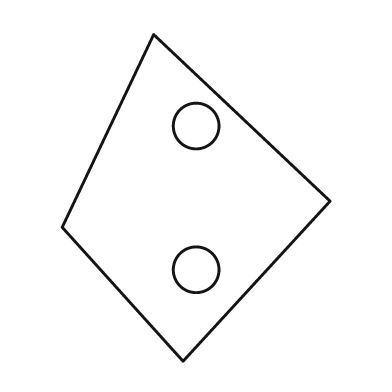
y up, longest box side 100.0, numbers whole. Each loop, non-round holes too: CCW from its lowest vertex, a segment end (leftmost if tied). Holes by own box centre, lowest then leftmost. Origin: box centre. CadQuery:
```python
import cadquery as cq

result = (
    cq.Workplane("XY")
    .moveTo(-4.0, -50.0)
    .lineTo(41.0, -1.0)
    .lineTo(-13.0, 50.0)
    .lineTo(-41.0, -9.0)
    .close()
    .moveTo(0.0, -22.0)
    .circle(7.0)
    .moveTo(0.0, 22.0)
    .circle(7.0)
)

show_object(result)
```